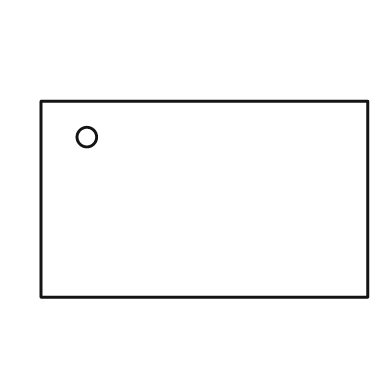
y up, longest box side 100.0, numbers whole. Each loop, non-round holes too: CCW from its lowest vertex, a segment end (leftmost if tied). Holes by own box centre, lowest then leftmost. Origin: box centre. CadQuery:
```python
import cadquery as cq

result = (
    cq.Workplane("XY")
    .moveTo(-50.0, -30.0)
    .lineTo(50.0, -30.0)
    .lineTo(50.0, 30.0)
    .lineTo(-50.0, 30.0)
    .close()
    .moveTo(-36.0, 19.0)
    .circle(3.0)
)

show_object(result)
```